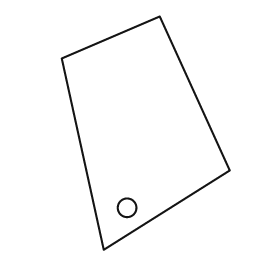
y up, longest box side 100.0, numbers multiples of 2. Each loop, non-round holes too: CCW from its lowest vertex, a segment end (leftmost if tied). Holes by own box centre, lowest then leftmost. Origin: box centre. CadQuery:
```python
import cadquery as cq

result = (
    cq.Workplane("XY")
    .moveTo(-18.0, -50.0)
    .lineTo(36.0, -16.0)
    .lineTo(6.0, 50.0)
    .lineTo(-36.0, 32.0)
    .close()
    .moveTo(-8.0, -32.0)
    .circle(4.0)
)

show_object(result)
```